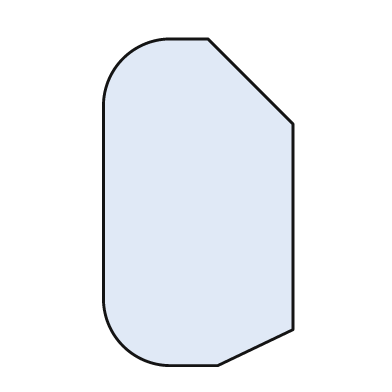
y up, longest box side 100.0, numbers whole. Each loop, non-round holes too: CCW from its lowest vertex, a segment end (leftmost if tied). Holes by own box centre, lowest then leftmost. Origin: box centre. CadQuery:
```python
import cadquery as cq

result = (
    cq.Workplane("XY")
    .moveTo(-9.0, -50.0)
    .lineTo(6.0, -50.0)
    .lineTo(29.0, -39.0)
    .lineTo(29.0, 24.0)
    .lineTo(3.0, 50.0)
    .lineTo(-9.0, 50.0)
    .threePointArc((-23.0, 44.0), (-29.0, 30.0))
    .lineTo(-29.0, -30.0)
    .threePointArc((-23.0, -44.0), (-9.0, -50.0))
    .close()
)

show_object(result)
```